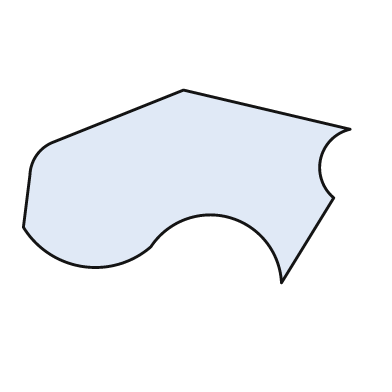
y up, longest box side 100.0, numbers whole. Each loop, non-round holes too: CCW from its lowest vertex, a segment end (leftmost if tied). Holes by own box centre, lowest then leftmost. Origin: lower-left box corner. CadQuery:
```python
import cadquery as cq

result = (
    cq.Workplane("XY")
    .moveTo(79.0, 0.0)
    .lineTo(95.0, 26.0)
    .threePointArc((91.0, 38.0), (100.0, 47.0))
    .lineTo(49.0, 59.0)
    .lineTo(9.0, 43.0)
    .threePointArc((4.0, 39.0), (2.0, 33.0))
    .lineTo(0.0, 17.0)
    .threePointArc((18.0, 5.0), (39.0, 11.0))
    .threePointArc((63.0, 20.0), (79.0, 0.0))
    .close()
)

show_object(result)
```